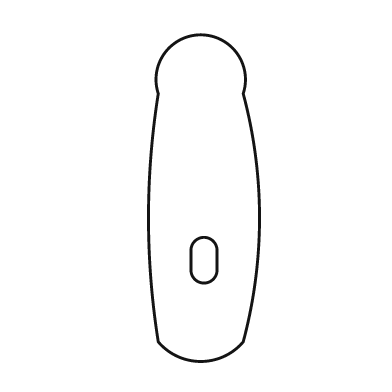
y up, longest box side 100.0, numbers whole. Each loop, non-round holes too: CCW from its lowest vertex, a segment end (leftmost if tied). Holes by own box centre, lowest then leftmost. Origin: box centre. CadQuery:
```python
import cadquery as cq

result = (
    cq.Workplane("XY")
    .moveTo(-14.0, -44.0)
    .threePointArc((-1.0, -50.0), (12.0, -44.0))
    .threePointArc((17.0, -6.0), (12.0, 32.0))
    .threePointArc((-1.0, 50.0), (-14.0, 32.0))
    .threePointArc((-17.0, -6.0), (-14.0, -44.0))
    .close()
    .moveTo(-4.0, -22.0)
    .threePointArc((0.0, -26.0), (4.0, -22.0))
    .lineTo(4.0, -16.0)
    .threePointArc((0.0, -12.0), (-4.0, -16.0))
    .close()
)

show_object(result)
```